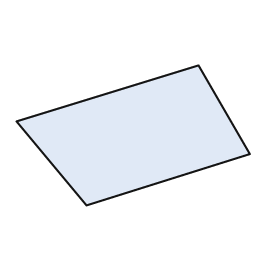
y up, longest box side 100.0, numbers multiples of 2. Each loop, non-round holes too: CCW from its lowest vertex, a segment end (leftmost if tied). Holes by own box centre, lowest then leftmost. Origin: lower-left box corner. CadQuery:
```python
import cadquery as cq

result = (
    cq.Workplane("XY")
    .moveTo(30.0, 0.0)
    .lineTo(100.0, 22.0)
    .lineTo(78.0, 60.0)
    .lineTo(0.0, 36.0)
    .close()
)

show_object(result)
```